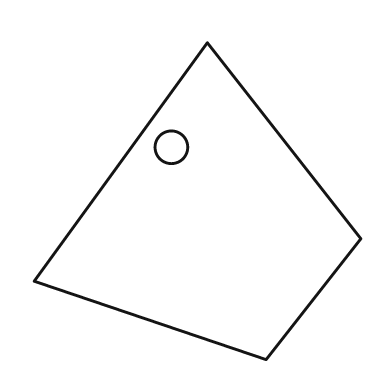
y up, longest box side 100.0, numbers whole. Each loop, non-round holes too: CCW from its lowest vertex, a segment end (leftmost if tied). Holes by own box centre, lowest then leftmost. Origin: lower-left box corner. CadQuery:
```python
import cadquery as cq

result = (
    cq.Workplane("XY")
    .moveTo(71.0, 0.0)
    .lineTo(100.0, 37.0)
    .lineTo(53.0, 97.0)
    .lineTo(0.0, 24.0)
    .close()
    .moveTo(42.0, 65.0)
    .circle(5.0)
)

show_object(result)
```